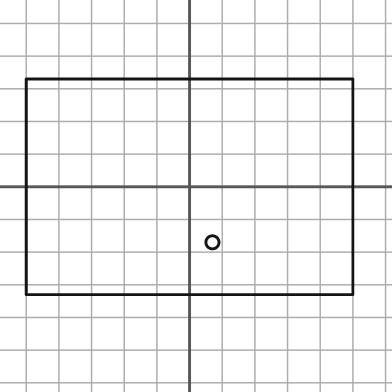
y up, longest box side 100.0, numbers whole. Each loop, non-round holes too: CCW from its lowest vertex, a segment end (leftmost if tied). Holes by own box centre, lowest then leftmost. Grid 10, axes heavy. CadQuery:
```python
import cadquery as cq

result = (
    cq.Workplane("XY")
    .moveTo(-50.0, -33.0)
    .lineTo(50.0, -33.0)
    .lineTo(50.0, 33.0)
    .lineTo(-50.0, 33.0)
    .close()
    .moveTo(7.0, -17.0)
    .circle(2.0)
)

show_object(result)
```